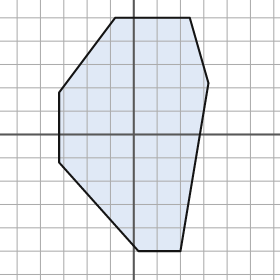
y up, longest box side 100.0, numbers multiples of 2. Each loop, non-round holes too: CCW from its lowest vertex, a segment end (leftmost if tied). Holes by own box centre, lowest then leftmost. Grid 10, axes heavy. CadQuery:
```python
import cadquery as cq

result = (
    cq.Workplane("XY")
    .moveTo(2.0, -50.0)
    .lineTo(20.0, -50.0)
    .lineTo(32.0, 22.0)
    .lineTo(24.0, 50.0)
    .lineTo(-8.0, 50.0)
    .lineTo(-32.0, 18.0)
    .lineTo(-32.0, -12.0)
    .close()
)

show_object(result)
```